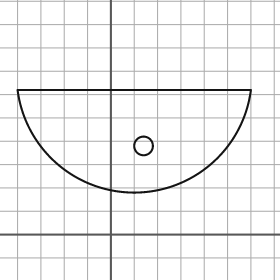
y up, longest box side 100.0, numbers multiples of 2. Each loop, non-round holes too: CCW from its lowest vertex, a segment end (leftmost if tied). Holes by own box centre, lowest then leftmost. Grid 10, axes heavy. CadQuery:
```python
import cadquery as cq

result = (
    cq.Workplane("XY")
    .moveTo(-40.0, 62.0)
    .threePointArc((10.0, 18.0), (60.0, 62.0))
    .close()
    .moveTo(14.0, 38.0)
    .circle(4.0)
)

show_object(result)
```